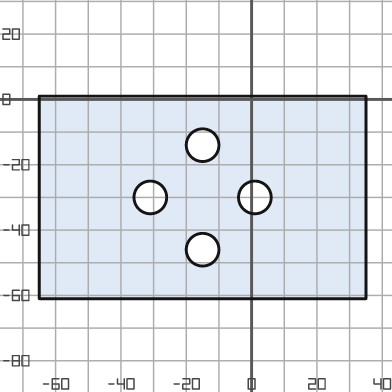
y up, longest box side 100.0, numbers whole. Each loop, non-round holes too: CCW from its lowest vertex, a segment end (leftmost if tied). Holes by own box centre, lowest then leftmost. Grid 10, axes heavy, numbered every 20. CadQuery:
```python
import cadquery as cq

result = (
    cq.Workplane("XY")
    .moveTo(-65.0, -61.0)
    .lineTo(35.0, -61.0)
    .lineTo(35.0, 1.0)
    .lineTo(-65.0, 1.0)
    .close()
    .moveTo(-15.0, -46.0)
    .circle(5.0)
    .moveTo(-31.0, -30.0)
    .circle(5.0)
    .moveTo(1.0, -30.0)
    .circle(5.0)
    .moveTo(-15.0, -14.0)
    .circle(5.0)
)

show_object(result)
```